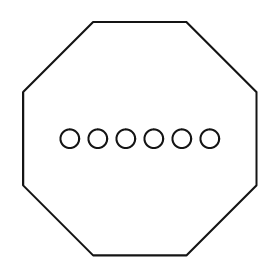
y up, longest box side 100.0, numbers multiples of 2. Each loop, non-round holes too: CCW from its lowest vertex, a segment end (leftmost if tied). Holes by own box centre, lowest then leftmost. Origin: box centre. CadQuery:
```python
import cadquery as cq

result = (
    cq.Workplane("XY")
    .moveTo(-20.0, -50.0)
    .lineTo(20.0, -50.0)
    .lineTo(50.0, -20.0)
    .lineTo(50.0, 20.0)
    .lineTo(20.0, 50.0)
    .lineTo(-20.0, 50.0)
    .lineTo(-50.0, 20.0)
    .lineTo(-50.0, -20.0)
    .close()
    .moveTo(-30.0, 0.0)
    .circle(4.0)
    .moveTo(-18.0, 0.0)
    .circle(4.0)
    .moveTo(-6.0, 0.0)
    .circle(4.0)
    .moveTo(6.0, 0.0)
    .circle(4.0)
    .moveTo(18.0, 0.0)
    .circle(4.0)
    .moveTo(30.0, 0.0)
    .circle(4.0)
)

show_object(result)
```